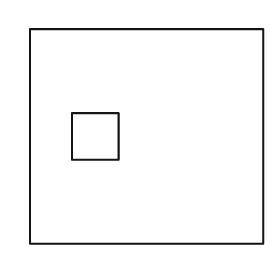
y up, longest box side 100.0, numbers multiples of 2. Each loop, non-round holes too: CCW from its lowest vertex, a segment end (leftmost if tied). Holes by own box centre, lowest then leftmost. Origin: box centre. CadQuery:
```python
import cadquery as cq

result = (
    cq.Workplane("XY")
    .moveTo(-50.0, -46.0)
    .lineTo(50.0, -46.0)
    .lineTo(50.0, 46.0)
    .lineTo(-50.0, 46.0)
    .close()
    .moveTo(-32.0, -10.0)
    .lineTo(-12.0, -10.0)
    .lineTo(-12.0, 10.0)
    .lineTo(-32.0, 10.0)
    .close()
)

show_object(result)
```